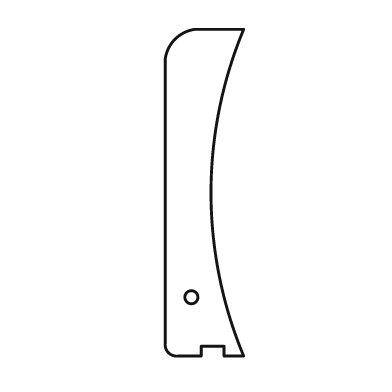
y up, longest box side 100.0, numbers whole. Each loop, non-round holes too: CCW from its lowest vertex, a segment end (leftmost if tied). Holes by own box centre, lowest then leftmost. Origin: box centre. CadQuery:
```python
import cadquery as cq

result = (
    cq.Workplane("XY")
    .moveTo(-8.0, -50.0)
    .lineTo(-1.0, -50.0)
    .lineTo(-1.0, -47.0)
    .lineTo(6.0, -47.0)
    .lineTo(6.0, -50.0)
    .lineTo(12.0, -50.0)
    .threePointArc((2.0, 0.0), (12.0, 50.0))
    .lineTo(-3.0, 50.0)
    .threePointArc((-9.0, 47.0), (-12.0, 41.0))
    .lineTo(-12.0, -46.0)
    .threePointArc((-11.0, -49.0), (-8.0, -50.0))
    .close()
    .moveTo(-4.0, -32.0)
    .circle(2.0)
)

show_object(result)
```